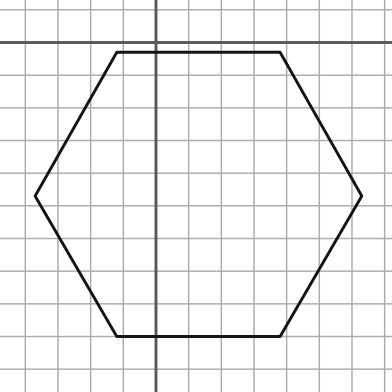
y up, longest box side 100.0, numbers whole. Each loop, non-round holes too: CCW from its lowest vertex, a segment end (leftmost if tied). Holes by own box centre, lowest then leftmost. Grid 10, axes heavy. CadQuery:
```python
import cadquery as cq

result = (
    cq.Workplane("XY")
    .moveTo(-12.0, -90.0)
    .lineTo(38.0, -90.0)
    .lineTo(63.0, -47.0)
    .lineTo(38.0, -3.0)
    .lineTo(-12.0, -3.0)
    .lineTo(-37.0, -47.0)
    .close()
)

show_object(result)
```